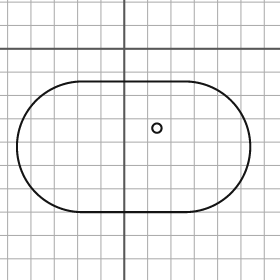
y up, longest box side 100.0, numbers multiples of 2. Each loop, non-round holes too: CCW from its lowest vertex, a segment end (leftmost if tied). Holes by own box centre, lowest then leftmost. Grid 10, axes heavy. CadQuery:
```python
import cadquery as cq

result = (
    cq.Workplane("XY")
    .moveTo(-18.0, -70.0)
    .lineTo(26.0, -70.0)
    .threePointArc((54.0, -42.0), (26.0, -14.0))
    .lineTo(-18.0, -14.0)
    .threePointArc((-46.0, -42.0), (-18.0, -70.0))
    .close()
    .moveTo(14.0, -34.0)
    .circle(2.0)
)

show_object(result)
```